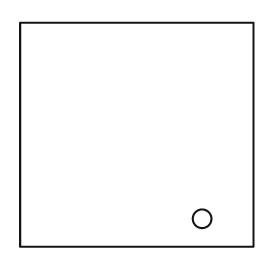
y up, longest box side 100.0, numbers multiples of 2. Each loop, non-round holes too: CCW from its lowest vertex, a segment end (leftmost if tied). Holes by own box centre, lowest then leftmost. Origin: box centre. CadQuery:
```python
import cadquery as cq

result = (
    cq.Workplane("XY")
    .moveTo(-50.0, -48.0)
    .lineTo(50.0, -48.0)
    .lineTo(50.0, 48.0)
    .lineTo(-50.0, 48.0)
    .close()
    .moveTo(28.0, -36.0)
    .circle(4.0)
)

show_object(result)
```